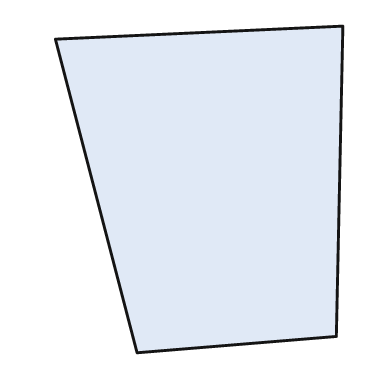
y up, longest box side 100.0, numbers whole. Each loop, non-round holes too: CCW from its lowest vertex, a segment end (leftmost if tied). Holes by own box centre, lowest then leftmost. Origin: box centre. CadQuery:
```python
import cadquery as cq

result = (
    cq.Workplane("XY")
    .moveTo(-19.0, -50.0)
    .lineTo(42.0, -45.0)
    .lineTo(44.0, 50.0)
    .lineTo(-44.0, 46.0)
    .close()
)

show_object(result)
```